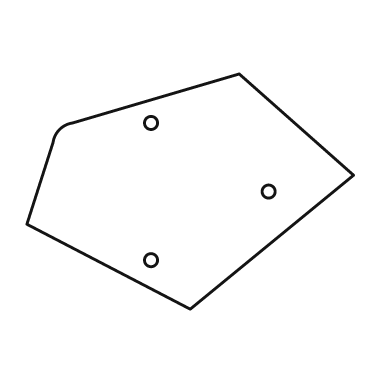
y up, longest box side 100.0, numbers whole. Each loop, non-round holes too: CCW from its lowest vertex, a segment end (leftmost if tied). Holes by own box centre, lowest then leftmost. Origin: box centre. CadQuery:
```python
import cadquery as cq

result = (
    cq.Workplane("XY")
    .moveTo(0.0, -36.0)
    .lineTo(50.0, 5.0)
    .lineTo(15.0, 36.0)
    .lineTo(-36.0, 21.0)
    .threePointArc((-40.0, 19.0), (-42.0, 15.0))
    .lineTo(-50.0, -10.0)
    .close()
    .moveTo(-12.0, -21.0)
    .circle(2.0)
    .moveTo(24.0, 0.0)
    .circle(2.0)
    .moveTo(-12.0, 21.0)
    .circle(2.0)
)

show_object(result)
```